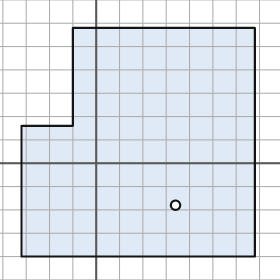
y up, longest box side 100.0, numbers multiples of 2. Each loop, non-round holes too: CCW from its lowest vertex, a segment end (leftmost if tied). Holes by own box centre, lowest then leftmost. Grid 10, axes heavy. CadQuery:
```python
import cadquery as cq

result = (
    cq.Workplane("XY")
    .moveTo(-32.0, -40.0)
    .lineTo(68.0, -40.0)
    .lineTo(68.0, 58.0)
    .lineTo(-10.0, 58.0)
    .lineTo(-10.0, 16.0)
    .lineTo(-32.0, 16.0)
    .close()
    .moveTo(34.0, -18.0)
    .circle(2.0)
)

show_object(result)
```